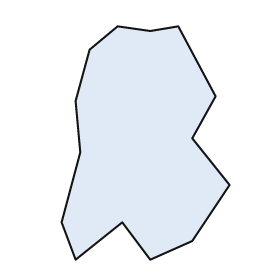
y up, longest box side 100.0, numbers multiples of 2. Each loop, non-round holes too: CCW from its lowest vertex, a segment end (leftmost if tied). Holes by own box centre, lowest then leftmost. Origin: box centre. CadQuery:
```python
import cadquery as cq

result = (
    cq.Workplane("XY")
    .moveTo(-30.0, -50.0)
    .lineTo(-10.0, -34.0)
    .lineTo(2.0, -50.0)
    .lineTo(20.0, -42.0)
    .lineTo(36.0, -18.0)
    .lineTo(20.0, 2.0)
    .lineTo(30.0, 20.0)
    .lineTo(14.0, 50.0)
    .lineTo(2.0, 48.0)
    .lineTo(-12.0, 50.0)
    .lineTo(-24.0, 40.0)
    .lineTo(-30.0, 18.0)
    .lineTo(-28.0, -4.0)
    .lineTo(-36.0, -34.0)
    .close()
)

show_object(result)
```